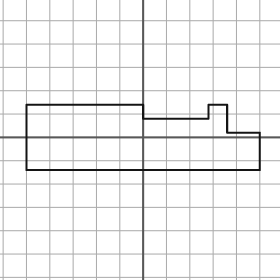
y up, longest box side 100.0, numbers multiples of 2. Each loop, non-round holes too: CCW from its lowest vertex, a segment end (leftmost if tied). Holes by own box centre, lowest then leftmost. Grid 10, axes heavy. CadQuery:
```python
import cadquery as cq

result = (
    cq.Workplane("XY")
    .moveTo(-50.0, -14.0)
    .lineTo(50.0, -14.0)
    .lineTo(50.0, 2.0)
    .lineTo(36.0, 2.0)
    .lineTo(36.0, 14.0)
    .lineTo(28.0, 14.0)
    .lineTo(28.0, 8.0)
    .lineTo(0.0, 8.0)
    .lineTo(0.0, 14.0)
    .lineTo(-50.0, 14.0)
    .close()
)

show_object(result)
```